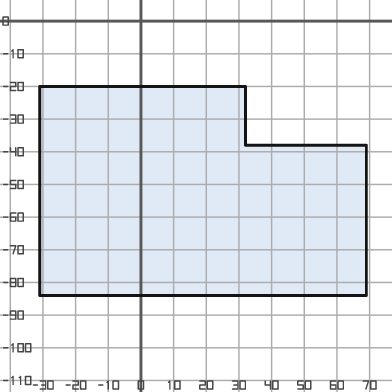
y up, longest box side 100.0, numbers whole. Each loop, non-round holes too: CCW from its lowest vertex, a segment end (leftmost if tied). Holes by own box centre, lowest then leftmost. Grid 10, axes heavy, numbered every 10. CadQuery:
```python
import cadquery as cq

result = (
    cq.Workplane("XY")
    .moveTo(-31.0, -84.0)
    .lineTo(69.0, -84.0)
    .lineTo(69.0, -38.0)
    .lineTo(32.0, -38.0)
    .lineTo(32.0, -20.0)
    .lineTo(-31.0, -20.0)
    .close()
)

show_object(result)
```